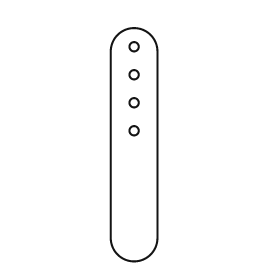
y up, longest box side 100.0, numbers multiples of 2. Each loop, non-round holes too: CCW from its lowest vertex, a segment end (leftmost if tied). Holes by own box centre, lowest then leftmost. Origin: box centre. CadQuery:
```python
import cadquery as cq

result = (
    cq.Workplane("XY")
    .moveTo(-10.0, -40.0)
    .threePointArc((0.0, -50.0), (10.0, -40.0))
    .lineTo(10.0, 40.0)
    .threePointArc((0.0, 50.0), (-10.0, 40.0))
    .close()
    .moveTo(0.0, 6.0)
    .circle(2.0)
    .moveTo(0.0, 18.0)
    .circle(2.0)
    .moveTo(0.0, 30.0)
    .circle(2.0)
    .moveTo(0.0, 42.0)
    .circle(2.0)
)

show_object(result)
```